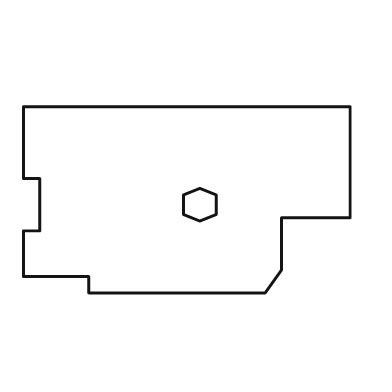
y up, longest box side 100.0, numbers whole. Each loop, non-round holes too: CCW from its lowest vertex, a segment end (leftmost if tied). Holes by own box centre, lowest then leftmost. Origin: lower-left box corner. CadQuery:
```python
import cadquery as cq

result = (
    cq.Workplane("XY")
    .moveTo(20.0, 0.0)
    .lineTo(74.0, 0.0)
    .lineTo(79.0, 7.0)
    .lineTo(79.0, 23.0)
    .lineTo(100.0, 23.0)
    .lineTo(100.0, 57.0)
    .lineTo(0.0, 57.0)
    .lineTo(0.0, 35.0)
    .lineTo(5.0, 35.0)
    .lineTo(5.0, 19.0)
    .lineTo(0.0, 19.0)
    .lineTo(0.0, 5.0)
    .lineTo(20.0, 5.0)
    .close()
    .moveTo(54.0, 22.0)
    .lineTo(59.0, 24.0)
    .lineTo(59.0, 30.0)
    .lineTo(54.0, 32.0)
    .lineTo(49.0, 30.0)
    .lineTo(49.0, 24.0)
    .close()
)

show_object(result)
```